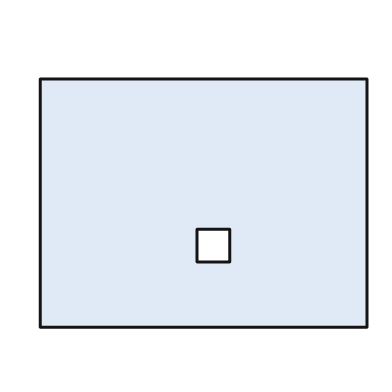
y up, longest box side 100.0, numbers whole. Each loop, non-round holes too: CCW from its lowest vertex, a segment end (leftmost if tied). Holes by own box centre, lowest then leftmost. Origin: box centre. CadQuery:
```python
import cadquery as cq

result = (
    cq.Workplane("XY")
    .moveTo(-50.0, -38.0)
    .lineTo(50.0, -38.0)
    .lineTo(50.0, 38.0)
    .lineTo(-50.0, 38.0)
    .close()
    .moveTo(-2.0, -18.0)
    .lineTo(8.0, -18.0)
    .lineTo(8.0, -8.0)
    .lineTo(-2.0, -8.0)
    .close()
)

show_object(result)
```